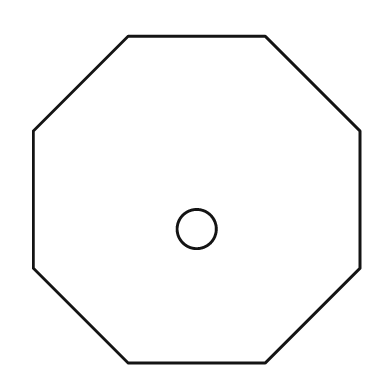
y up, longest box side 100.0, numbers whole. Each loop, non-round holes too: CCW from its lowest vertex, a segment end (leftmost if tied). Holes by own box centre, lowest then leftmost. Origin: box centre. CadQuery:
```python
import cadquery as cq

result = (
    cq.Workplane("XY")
    .moveTo(-21.0, -50.0)
    .lineTo(21.0, -50.0)
    .lineTo(50.0, -21.0)
    .lineTo(50.0, 21.0)
    .lineTo(21.0, 50.0)
    .lineTo(-21.0, 50.0)
    .lineTo(-50.0, 21.0)
    .lineTo(-50.0, -21.0)
    .close()
    .moveTo(0.0, -9.0)
    .circle(6.0)
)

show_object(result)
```